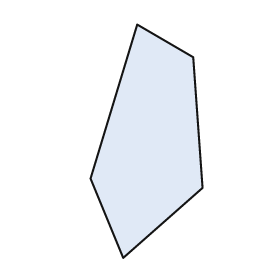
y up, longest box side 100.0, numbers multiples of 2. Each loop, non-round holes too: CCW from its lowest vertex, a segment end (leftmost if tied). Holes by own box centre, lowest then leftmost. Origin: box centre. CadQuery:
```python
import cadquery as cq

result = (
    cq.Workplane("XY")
    .moveTo(-10.0, -50.0)
    .lineTo(24.0, -20.0)
    .lineTo(20.0, 36.0)
    .lineTo(-4.0, 50.0)
    .lineTo(-24.0, -16.0)
    .close()
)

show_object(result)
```